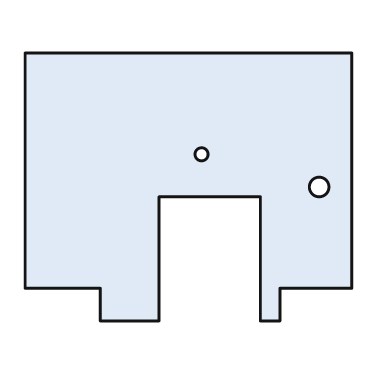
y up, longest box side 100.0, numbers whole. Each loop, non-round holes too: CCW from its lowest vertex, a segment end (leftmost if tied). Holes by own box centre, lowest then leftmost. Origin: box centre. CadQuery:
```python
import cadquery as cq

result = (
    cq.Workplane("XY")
    .moveTo(-27.0, -41.0)
    .lineTo(-9.0, -41.0)
    .lineTo(-9.0, -3.0)
    .lineTo(22.0, -3.0)
    .lineTo(22.0, -41.0)
    .lineTo(28.0, -41.0)
    .lineTo(28.0, -31.0)
    .lineTo(50.0, -31.0)
    .lineTo(50.0, 41.0)
    .lineTo(-50.0, 41.0)
    .lineTo(-50.0, -31.0)
    .lineTo(-27.0, -31.0)
    .close()
    .moveTo(40.0, 0.0)
    .circle(3.0)
    .moveTo(4.0, 10.0)
    .circle(2.0)
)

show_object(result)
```